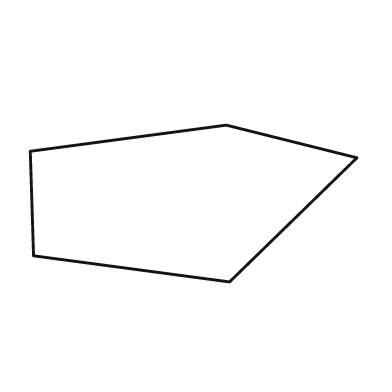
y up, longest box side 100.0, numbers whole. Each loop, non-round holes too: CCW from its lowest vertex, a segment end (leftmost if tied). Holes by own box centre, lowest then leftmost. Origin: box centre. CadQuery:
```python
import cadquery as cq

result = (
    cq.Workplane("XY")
    .moveTo(11.0, -24.0)
    .lineTo(50.0, 14.0)
    .lineTo(10.0, 24.0)
    .lineTo(-50.0, 16.0)
    .lineTo(-49.0, -16.0)
    .close()
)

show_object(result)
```